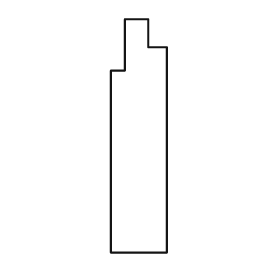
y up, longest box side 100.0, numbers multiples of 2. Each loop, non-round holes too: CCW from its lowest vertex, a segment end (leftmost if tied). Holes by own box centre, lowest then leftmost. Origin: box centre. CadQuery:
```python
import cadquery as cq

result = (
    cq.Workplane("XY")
    .moveTo(-12.0, -50.0)
    .lineTo(12.0, -50.0)
    .lineTo(12.0, 38.0)
    .lineTo(4.0, 38.0)
    .lineTo(4.0, 50.0)
    .lineTo(-6.0, 50.0)
    .lineTo(-6.0, 28.0)
    .lineTo(-12.0, 28.0)
    .close()
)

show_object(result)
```